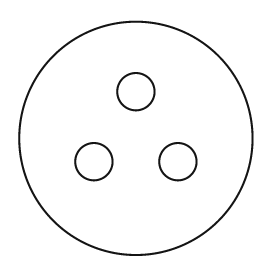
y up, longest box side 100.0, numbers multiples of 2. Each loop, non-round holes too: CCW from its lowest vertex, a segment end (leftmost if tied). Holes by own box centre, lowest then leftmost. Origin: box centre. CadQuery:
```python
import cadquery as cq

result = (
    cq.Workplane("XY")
    .moveTo(0.0, 0.0)
    .circle(50.0)
    .moveTo(-18.0, -10.0)
    .circle(8.0)
    .moveTo(18.0, -10.0)
    .circle(8.0)
    .moveTo(0.0, 20.0)
    .circle(8.0)
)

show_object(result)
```